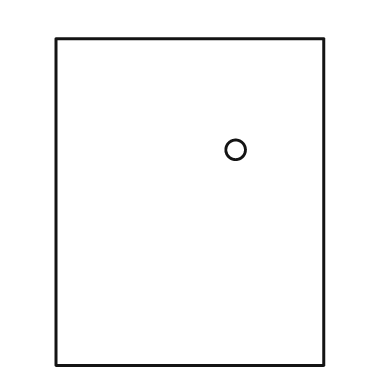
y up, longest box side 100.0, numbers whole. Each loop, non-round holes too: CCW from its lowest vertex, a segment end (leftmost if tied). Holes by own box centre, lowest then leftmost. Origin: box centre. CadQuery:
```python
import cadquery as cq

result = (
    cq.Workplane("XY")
    .moveTo(-41.0, -50.0)
    .lineTo(41.0, -50.0)
    .lineTo(41.0, 50.0)
    .lineTo(-41.0, 50.0)
    .close()
    .moveTo(14.0, 16.0)
    .circle(3.0)
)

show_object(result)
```